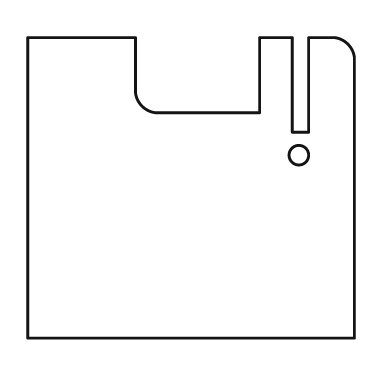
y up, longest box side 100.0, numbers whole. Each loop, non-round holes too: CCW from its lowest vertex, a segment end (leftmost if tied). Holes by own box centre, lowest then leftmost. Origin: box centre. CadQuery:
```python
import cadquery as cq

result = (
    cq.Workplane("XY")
    .moveTo(-50.0, -46.0)
    .lineTo(50.0, -46.0)
    .lineTo(50.0, 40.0)
    .threePointArc((48.0, 44.0), (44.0, 46.0))
    .lineTo(36.0, 46.0)
    .lineTo(36.0, 17.0)
    .lineTo(31.0, 17.0)
    .lineTo(31.0, 46.0)
    .lineTo(21.0, 46.0)
    .lineTo(21.0, 23.0)
    .lineTo(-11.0, 23.0)
    .threePointArc((-15.0, 25.0), (-17.0, 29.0))
    .lineTo(-17.0, 46.0)
    .lineTo(-50.0, 46.0)
    .close()
    .moveTo(33.0, 10.0)
    .circle(3.0)
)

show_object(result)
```